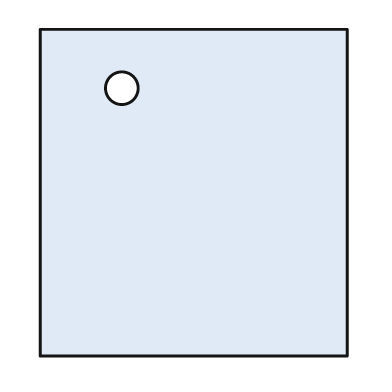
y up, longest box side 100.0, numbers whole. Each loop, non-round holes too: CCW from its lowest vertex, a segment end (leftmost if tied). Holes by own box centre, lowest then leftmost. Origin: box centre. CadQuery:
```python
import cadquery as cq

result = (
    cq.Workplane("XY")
    .moveTo(-47.0, -50.0)
    .lineTo(47.0, -50.0)
    .lineTo(47.0, 50.0)
    .lineTo(-47.0, 50.0)
    .close()
    .moveTo(-22.0, 32.0)
    .circle(5.0)
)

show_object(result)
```